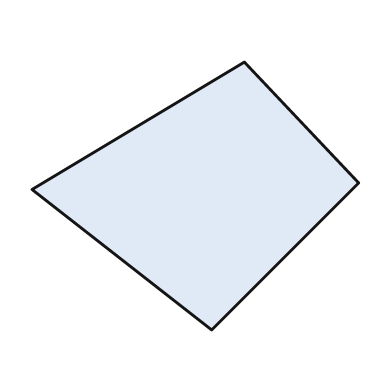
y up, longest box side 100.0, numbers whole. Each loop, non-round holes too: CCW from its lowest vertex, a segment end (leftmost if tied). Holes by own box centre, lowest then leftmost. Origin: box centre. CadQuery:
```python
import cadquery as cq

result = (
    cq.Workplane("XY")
    .moveTo(5.0, -41.0)
    .lineTo(50.0, 4.0)
    .lineTo(15.0, 41.0)
    .lineTo(-50.0, 2.0)
    .close()
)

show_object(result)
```